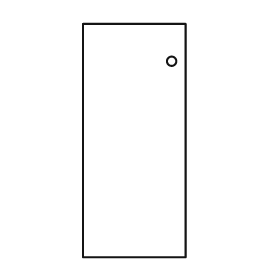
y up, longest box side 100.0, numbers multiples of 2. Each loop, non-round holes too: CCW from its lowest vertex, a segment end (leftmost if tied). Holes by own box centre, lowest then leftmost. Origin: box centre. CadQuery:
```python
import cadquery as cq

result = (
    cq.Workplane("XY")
    .moveTo(-22.0, -50.0)
    .lineTo(22.0, -50.0)
    .lineTo(22.0, 50.0)
    .lineTo(-22.0, 50.0)
    .close()
    .moveTo(16.0, 34.0)
    .circle(2.0)
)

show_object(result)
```